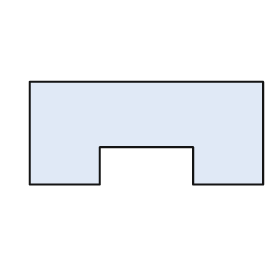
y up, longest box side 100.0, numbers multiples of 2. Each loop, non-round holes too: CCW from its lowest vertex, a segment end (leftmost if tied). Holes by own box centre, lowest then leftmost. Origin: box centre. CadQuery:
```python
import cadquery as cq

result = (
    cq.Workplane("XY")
    .moveTo(-50.0, -22.0)
    .lineTo(-20.0, -22.0)
    .lineTo(-20.0, -6.0)
    .lineTo(20.0, -6.0)
    .lineTo(20.0, -22.0)
    .lineTo(50.0, -22.0)
    .lineTo(50.0, 22.0)
    .lineTo(-50.0, 22.0)
    .close()
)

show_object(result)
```